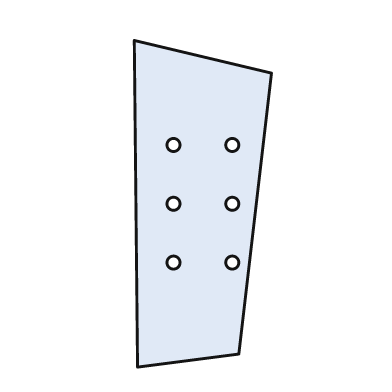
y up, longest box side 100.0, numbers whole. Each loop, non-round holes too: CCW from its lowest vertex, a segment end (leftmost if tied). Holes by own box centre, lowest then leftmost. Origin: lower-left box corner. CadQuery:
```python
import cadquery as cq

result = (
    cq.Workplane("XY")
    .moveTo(1.0, 0.0)
    .lineTo(32.0, 4.0)
    .lineTo(42.0, 90.0)
    .lineTo(0.0, 100.0)
    .close()
    .moveTo(12.0, 32.0)
    .circle(2.0)
    .moveTo(30.0, 32.0)
    .circle(2.0)
    .moveTo(12.0, 50.0)
    .circle(2.0)
    .moveTo(30.0, 50.0)
    .circle(2.0)
    .moveTo(12.0, 68.0)
    .circle(2.0)
    .moveTo(30.0, 68.0)
    .circle(2.0)
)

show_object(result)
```